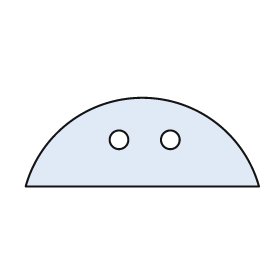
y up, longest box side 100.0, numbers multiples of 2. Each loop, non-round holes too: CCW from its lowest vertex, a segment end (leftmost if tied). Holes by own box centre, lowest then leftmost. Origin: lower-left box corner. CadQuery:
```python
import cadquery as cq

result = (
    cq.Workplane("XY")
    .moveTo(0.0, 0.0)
    .lineTo(100.0, 0.0)
    .threePointArc((50.0, 38.0), (0.0, 0.0))
    .close()
    .moveTo(40.0, 20.0)
    .circle(4.0)
    .moveTo(62.0, 20.0)
    .circle(4.0)
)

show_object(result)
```